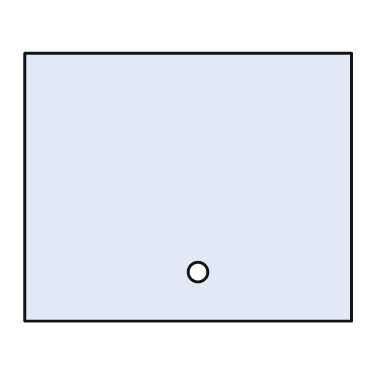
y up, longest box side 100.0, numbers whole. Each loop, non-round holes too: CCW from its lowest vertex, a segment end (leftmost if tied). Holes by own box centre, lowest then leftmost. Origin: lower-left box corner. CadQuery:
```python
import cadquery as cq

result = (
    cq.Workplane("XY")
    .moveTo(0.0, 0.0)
    .lineTo(100.0, 0.0)
    .lineTo(100.0, 82.0)
    .lineTo(0.0, 82.0)
    .close()
    .moveTo(53.0, 15.0)
    .circle(3.0)
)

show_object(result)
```